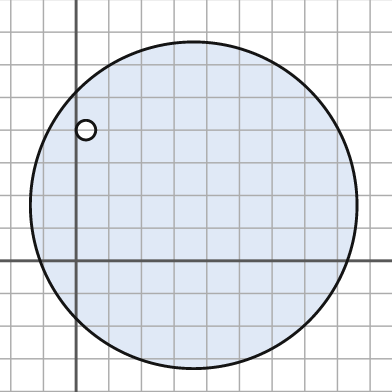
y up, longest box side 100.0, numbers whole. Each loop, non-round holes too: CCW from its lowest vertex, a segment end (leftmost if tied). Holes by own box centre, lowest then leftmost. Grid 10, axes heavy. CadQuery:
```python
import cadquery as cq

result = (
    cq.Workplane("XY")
    .moveTo(36.0, 17.0)
    .circle(50.0)
    .moveTo(3.0, 40.0)
    .circle(3.0)
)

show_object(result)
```